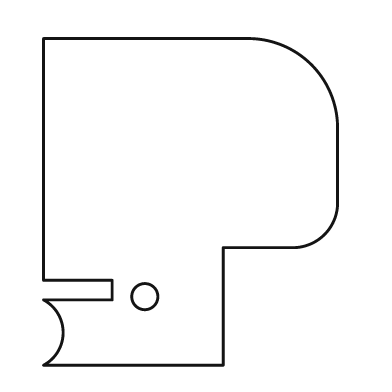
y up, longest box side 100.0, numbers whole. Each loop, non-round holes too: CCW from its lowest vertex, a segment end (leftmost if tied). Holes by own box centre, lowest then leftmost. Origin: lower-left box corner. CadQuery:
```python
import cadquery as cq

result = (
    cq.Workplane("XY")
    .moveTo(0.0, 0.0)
    .lineTo(55.0, 0.0)
    .lineTo(55.0, 36.0)
    .lineTo(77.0, 36.0)
    .threePointArc((86.0, 40.0), (90.0, 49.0))
    .lineTo(90.0, 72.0)
    .threePointArc((82.0, 92.0), (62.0, 100.0))
    .lineTo(0.0, 100.0)
    .lineTo(0.0, 26.0)
    .lineTo(21.0, 26.0)
    .lineTo(21.0, 20.0)
    .lineTo(0.0, 20.0)
    .threePointArc((6.0, 10.0), (0.0, 0.0))
    .close()
    .moveTo(31.0, 21.0)
    .circle(4.0)
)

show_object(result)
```